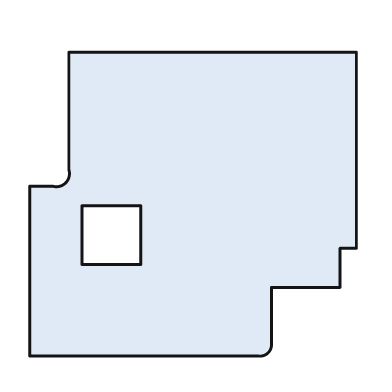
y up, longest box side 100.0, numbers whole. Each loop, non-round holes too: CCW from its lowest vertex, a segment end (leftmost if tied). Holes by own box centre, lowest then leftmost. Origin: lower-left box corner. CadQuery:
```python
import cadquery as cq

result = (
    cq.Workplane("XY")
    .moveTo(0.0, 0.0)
    .lineTo(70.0, 0.0)
    .threePointArc((73.0, 1.0), (74.0, 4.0))
    .lineTo(74.0, 21.0)
    .lineTo(95.0, 21.0)
    .lineTo(95.0, 33.0)
    .lineTo(100.0, 33.0)
    .lineTo(100.0, 93.0)
    .lineTo(12.0, 93.0)
    .lineTo(12.0, 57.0)
    .threePointArc((11.0, 53.0), (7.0, 52.0))
    .lineTo(0.0, 52.0)
    .close()
    .moveTo(16.0, 28.0)
    .lineTo(34.0, 28.0)
    .lineTo(34.0, 46.0)
    .lineTo(16.0, 46.0)
    .close()
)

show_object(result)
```